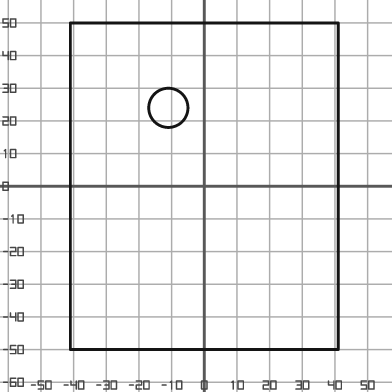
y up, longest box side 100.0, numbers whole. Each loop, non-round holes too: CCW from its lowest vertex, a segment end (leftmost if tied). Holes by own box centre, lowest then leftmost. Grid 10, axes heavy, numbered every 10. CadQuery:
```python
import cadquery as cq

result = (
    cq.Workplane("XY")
    .moveTo(-41.0, -50.0)
    .lineTo(41.0, -50.0)
    .lineTo(41.0, 50.0)
    .lineTo(-41.0, 50.0)
    .close()
    .moveTo(-11.0, 24.0)
    .circle(6.0)
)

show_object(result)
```